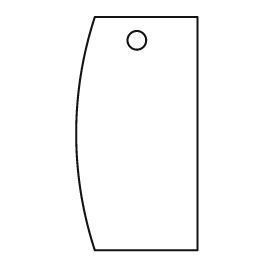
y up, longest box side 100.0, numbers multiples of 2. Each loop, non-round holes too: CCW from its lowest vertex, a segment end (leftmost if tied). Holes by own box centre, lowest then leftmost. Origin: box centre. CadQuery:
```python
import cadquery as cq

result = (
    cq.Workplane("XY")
    .moveTo(-18.0, -50.0)
    .lineTo(26.0, -50.0)
    .lineTo(26.0, 50.0)
    .lineTo(-18.0, 50.0)
    .threePointArc((-26.0, 0.0), (-18.0, -50.0))
    .close()
    .moveTo(0.0, 40.0)
    .circle(4.0)
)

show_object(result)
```